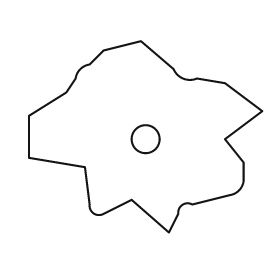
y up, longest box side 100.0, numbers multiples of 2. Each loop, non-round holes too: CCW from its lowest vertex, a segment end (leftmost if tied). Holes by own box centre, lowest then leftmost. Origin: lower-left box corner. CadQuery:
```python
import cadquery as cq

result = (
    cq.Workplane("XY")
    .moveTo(60.0, 0.0)
    .lineTo(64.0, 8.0)
    .threePointArc((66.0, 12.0), (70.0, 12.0))
    .lineTo(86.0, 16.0)
    .threePointArc((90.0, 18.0), (92.0, 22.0))
    .lineTo(92.0, 30.0)
    .lineTo(84.0, 40.0)
    .lineTo(100.0, 52.0)
    .lineTo(84.0, 64.0)
    .lineTo(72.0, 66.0)
    .threePointArc((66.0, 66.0), (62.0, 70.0))
    .lineTo(48.0, 82.0)
    .lineTo(32.0, 78.0)
    .lineTo(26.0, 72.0)
    .threePointArc((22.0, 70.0), (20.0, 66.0))
    .lineTo(16.0, 60.0)
    .lineTo(0.0, 50.0)
    .lineTo(0.0, 32.0)
    .lineTo(24.0, 28.0)
    .lineTo(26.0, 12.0)
    .threePointArc((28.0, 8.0), (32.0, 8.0))
    .lineTo(44.0, 14.0)
    .close()
    .moveTo(50.0, 40.0)
    .circle(6.0)
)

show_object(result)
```